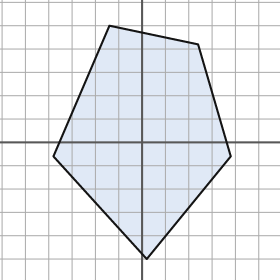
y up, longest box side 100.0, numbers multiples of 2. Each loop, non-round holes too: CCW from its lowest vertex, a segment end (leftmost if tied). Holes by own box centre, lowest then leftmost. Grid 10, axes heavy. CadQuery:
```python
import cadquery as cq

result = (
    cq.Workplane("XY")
    .moveTo(2.0, -50.0)
    .lineTo(38.0, -6.0)
    .lineTo(24.0, 42.0)
    .lineTo(-14.0, 50.0)
    .lineTo(-38.0, -6.0)
    .close()
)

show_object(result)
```